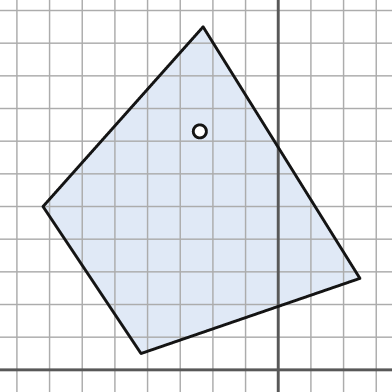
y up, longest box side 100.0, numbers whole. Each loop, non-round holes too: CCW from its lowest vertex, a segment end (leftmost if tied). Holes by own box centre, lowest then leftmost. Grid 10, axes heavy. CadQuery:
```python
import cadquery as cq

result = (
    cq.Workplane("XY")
    .moveTo(-42.0, 5.0)
    .lineTo(25.0, 28.0)
    .lineTo(-23.0, 105.0)
    .lineTo(-72.0, 50.0)
    .close()
    .moveTo(-24.0, 73.0)
    .circle(2.0)
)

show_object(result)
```